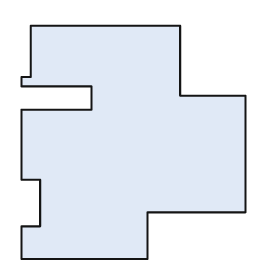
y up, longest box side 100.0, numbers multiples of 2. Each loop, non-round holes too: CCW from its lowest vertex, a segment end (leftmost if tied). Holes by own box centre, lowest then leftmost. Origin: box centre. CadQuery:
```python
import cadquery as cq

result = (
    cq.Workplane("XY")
    .moveTo(-48.0, -50.0)
    .lineTo(6.0, -50.0)
    .lineTo(6.0, -30.0)
    .lineTo(48.0, -30.0)
    .lineTo(48.0, 20.0)
    .lineTo(20.0, 20.0)
    .lineTo(20.0, 50.0)
    .lineTo(-44.0, 50.0)
    .lineTo(-44.0, 28.0)
    .lineTo(-48.0, 28.0)
    .lineTo(-48.0, 24.0)
    .lineTo(-18.0, 24.0)
    .lineTo(-18.0, 14.0)
    .lineTo(-48.0, 14.0)
    .lineTo(-48.0, -16.0)
    .lineTo(-40.0, -16.0)
    .lineTo(-40.0, -36.0)
    .lineTo(-48.0, -36.0)
    .close()
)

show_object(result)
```